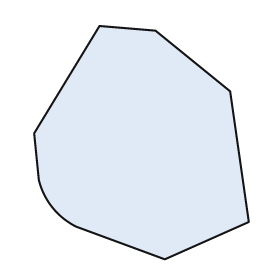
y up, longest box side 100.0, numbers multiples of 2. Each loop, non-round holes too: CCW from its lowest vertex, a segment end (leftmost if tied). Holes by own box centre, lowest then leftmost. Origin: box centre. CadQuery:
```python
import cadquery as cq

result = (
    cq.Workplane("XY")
    .moveTo(10.0, -50.0)
    .lineTo(46.0, -34.0)
    .lineTo(38.0, 22.0)
    .lineTo(6.0, 48.0)
    .lineTo(-18.0, 50.0)
    .lineTo(-46.0, 4.0)
    .lineTo(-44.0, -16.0)
    .threePointArc((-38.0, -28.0), (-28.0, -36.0))
    .close()
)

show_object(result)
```